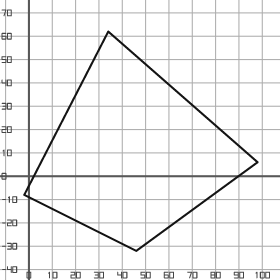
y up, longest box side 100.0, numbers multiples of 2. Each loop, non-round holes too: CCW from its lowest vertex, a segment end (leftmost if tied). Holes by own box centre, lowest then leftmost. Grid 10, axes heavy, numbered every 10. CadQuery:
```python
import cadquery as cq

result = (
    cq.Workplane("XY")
    .moveTo(46.0, -32.0)
    .lineTo(98.0, 6.0)
    .lineTo(34.0, 62.0)
    .lineTo(-2.0, -8.0)
    .close()
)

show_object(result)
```